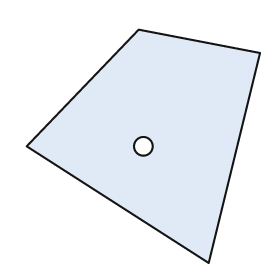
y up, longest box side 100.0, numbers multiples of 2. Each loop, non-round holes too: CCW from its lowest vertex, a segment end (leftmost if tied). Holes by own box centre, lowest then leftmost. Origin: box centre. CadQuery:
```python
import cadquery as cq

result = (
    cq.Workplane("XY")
    .moveTo(28.0, -50.0)
    .lineTo(50.0, 40.0)
    .lineTo(-2.0, 50.0)
    .lineTo(-50.0, 0.0)
    .close()
    .moveTo(0.0, 0.0)
    .circle(4.0)
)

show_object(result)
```